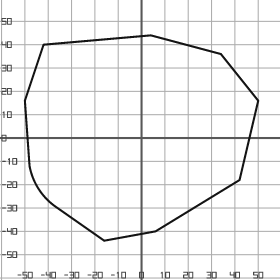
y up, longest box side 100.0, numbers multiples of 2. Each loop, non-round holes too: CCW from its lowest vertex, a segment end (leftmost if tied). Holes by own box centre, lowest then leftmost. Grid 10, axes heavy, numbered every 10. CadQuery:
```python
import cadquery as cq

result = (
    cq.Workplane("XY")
    .moveTo(-16.0, -44.0)
    .lineTo(6.0, -40.0)
    .lineTo(42.0, -18.0)
    .lineTo(50.0, 16.0)
    .lineTo(34.0, 36.0)
    .lineTo(4.0, 44.0)
    .lineTo(-42.0, 40.0)
    .lineTo(-50.0, 16.0)
    .lineTo(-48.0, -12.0)
    .threePointArc((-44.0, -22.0), (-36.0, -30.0))
    .close()
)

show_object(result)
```